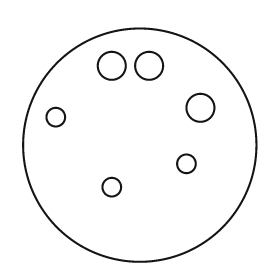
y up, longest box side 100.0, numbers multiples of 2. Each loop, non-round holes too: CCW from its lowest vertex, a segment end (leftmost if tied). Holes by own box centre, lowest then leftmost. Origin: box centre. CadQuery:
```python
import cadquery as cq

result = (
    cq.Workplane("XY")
    .moveTo(0.0, 0.0)
    .circle(50.0)
    .moveTo(-12.0, -18.0)
    .circle(4.0)
    .moveTo(20.0, -8.0)
    .circle(4.0)
    .moveTo(-36.0, 12.0)
    .circle(4.0)
    .moveTo(26.0, 16.0)
    .circle(6.0)
    .moveTo(-12.0, 34.0)
    .circle(6.0)
    .moveTo(4.0, 34.0)
    .circle(6.0)
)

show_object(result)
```